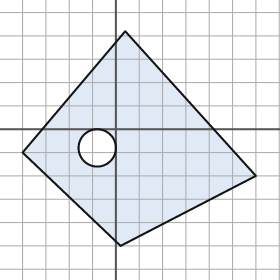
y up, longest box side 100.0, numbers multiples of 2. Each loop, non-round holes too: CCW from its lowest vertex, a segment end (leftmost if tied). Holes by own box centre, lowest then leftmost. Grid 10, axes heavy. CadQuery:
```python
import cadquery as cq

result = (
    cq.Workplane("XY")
    .moveTo(2.0, -50.0)
    .lineTo(60.0, -20.0)
    .lineTo(4.0, 42.0)
    .lineTo(-40.0, -10.0)
    .close()
    .moveTo(-8.0, -8.0)
    .circle(8.0)
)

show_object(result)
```